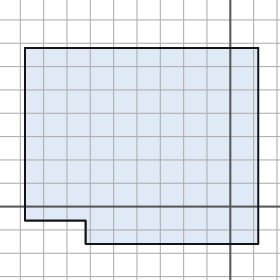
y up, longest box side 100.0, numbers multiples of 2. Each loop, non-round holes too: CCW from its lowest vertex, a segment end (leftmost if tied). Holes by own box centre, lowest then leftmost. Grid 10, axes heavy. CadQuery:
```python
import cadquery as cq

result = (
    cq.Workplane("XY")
    .moveTo(-62.0, -16.0)
    .lineTo(12.0, -16.0)
    .lineTo(12.0, 68.0)
    .lineTo(-88.0, 68.0)
    .lineTo(-88.0, -6.0)
    .lineTo(-62.0, -6.0)
    .close()
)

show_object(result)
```